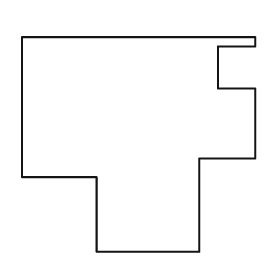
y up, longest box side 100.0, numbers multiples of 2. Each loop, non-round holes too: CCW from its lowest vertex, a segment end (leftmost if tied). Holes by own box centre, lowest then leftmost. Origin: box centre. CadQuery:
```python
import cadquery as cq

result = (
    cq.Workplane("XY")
    .moveTo(-18.0, -46.0)
    .lineTo(26.0, -46.0)
    .lineTo(26.0, -6.0)
    .lineTo(50.0, -6.0)
    .lineTo(50.0, 24.0)
    .lineTo(34.0, 24.0)
    .lineTo(34.0, 42.0)
    .lineTo(50.0, 42.0)
    .lineTo(50.0, 46.0)
    .lineTo(-50.0, 46.0)
    .lineTo(-50.0, -14.0)
    .lineTo(-18.0, -14.0)
    .close()
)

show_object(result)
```